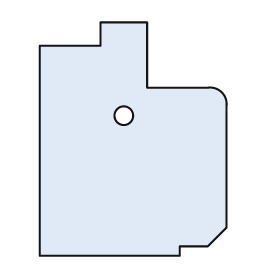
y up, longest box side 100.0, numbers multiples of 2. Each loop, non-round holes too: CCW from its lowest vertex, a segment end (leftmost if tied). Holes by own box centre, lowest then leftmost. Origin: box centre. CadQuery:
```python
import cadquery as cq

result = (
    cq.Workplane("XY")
    .moveTo(-40.0, -50.0)
    .lineTo(20.0, -50.0)
    .lineTo(20.0, -46.0)
    .lineTo(32.0, -46.0)
    .lineTo(40.0, -38.0)
    .lineTo(40.0, 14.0)
    .threePointArc((38.0, 20.0), (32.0, 22.0))
    .lineTo(6.0, 22.0)
    .lineTo(6.0, 50.0)
    .lineTo(-14.0, 50.0)
    .lineTo(-14.0, 40.0)
    .lineTo(-40.0, 40.0)
    .close()
    .moveTo(-4.0, 10.0)
    .circle(4.0)
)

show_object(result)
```